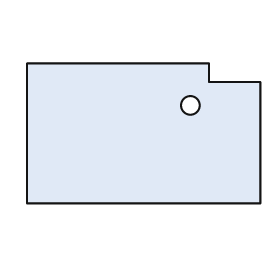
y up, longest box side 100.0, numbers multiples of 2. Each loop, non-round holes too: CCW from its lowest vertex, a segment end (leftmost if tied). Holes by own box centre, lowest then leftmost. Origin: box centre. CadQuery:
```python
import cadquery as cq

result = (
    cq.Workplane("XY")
    .moveTo(-50.0, -30.0)
    .lineTo(50.0, -30.0)
    .lineTo(50.0, 22.0)
    .lineTo(28.0, 22.0)
    .lineTo(28.0, 30.0)
    .lineTo(-50.0, 30.0)
    .close()
    .moveTo(20.0, 12.0)
    .circle(4.0)
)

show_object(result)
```